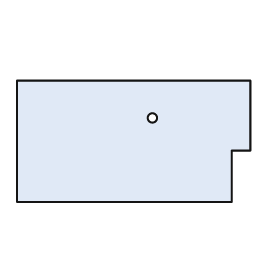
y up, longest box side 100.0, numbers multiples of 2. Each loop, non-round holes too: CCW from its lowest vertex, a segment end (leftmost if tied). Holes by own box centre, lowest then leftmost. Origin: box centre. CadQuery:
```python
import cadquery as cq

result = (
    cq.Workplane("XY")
    .moveTo(-50.0, -26.0)
    .lineTo(42.0, -26.0)
    .lineTo(42.0, -4.0)
    .lineTo(50.0, -4.0)
    .lineTo(50.0, 26.0)
    .lineTo(-50.0, 26.0)
    .close()
    .moveTo(8.0, 10.0)
    .circle(2.0)
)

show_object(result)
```